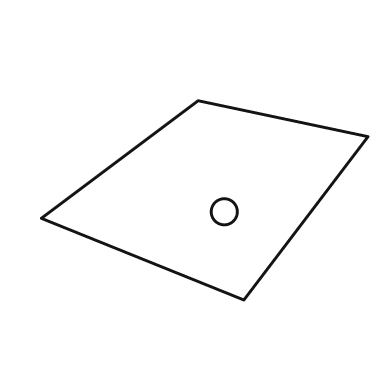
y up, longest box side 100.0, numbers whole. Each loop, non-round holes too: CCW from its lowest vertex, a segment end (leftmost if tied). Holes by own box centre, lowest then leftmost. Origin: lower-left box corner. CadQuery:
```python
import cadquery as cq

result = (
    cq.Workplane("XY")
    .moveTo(62.0, 0.0)
    .lineTo(100.0, 50.0)
    .lineTo(48.0, 61.0)
    .lineTo(0.0, 25.0)
    .close()
    .moveTo(56.0, 27.0)
    .circle(4.0)
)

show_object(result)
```